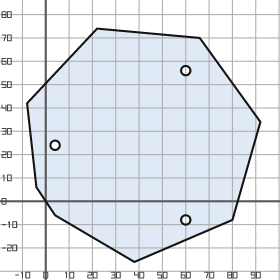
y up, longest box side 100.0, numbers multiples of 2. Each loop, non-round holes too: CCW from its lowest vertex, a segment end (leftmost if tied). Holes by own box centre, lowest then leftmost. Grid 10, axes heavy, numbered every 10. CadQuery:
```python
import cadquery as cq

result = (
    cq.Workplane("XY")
    .moveTo(38.0, -26.0)
    .lineTo(80.0, -8.0)
    .lineTo(92.0, 34.0)
    .lineTo(66.0, 70.0)
    .lineTo(22.0, 74.0)
    .lineTo(-8.0, 42.0)
    .lineTo(-4.0, 6.0)
    .lineTo(4.0, -6.0)
    .close()
    .moveTo(60.0, -8.0)
    .circle(2.0)
    .moveTo(4.0, 24.0)
    .circle(2.0)
    .moveTo(60.0, 56.0)
    .circle(2.0)
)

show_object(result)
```